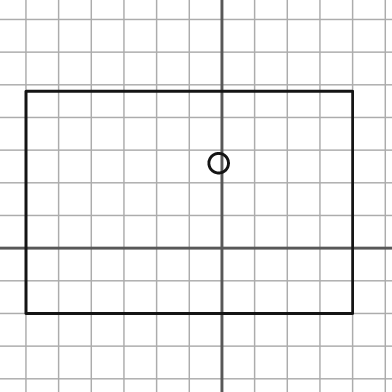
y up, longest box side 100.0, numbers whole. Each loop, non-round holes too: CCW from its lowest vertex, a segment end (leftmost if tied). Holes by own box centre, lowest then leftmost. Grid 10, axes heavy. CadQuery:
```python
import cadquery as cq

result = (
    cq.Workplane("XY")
    .moveTo(-60.0, -20.0)
    .lineTo(40.0, -20.0)
    .lineTo(40.0, 48.0)
    .lineTo(-60.0, 48.0)
    .close()
    .moveTo(-1.0, 26.0)
    .circle(3.0)
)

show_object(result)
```